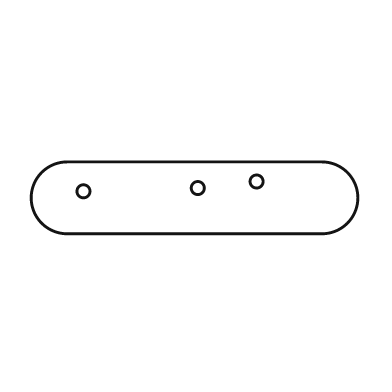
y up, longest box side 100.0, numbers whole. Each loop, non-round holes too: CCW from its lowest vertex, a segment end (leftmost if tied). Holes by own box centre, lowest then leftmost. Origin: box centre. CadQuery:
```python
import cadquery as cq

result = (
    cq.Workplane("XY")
    .moveTo(-39.0, -11.0)
    .lineTo(39.0, -11.0)
    .threePointArc((50.0, 0.0), (39.0, 11.0))
    .lineTo(-39.0, 11.0)
    .threePointArc((-50.0, 0.0), (-39.0, -11.0))
    .close()
    .moveTo(-34.0, 2.0)
    .circle(2.0)
    .moveTo(1.0, 3.0)
    .circle(2.0)
    .moveTo(19.0, 5.0)
    .circle(2.0)
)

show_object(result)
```